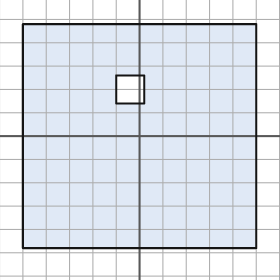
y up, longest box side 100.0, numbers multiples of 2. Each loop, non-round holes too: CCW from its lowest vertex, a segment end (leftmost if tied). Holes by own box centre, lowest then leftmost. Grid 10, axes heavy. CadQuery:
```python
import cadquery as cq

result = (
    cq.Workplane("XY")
    .moveTo(-50.0, -48.0)
    .lineTo(50.0, -48.0)
    .lineTo(50.0, 48.0)
    .lineTo(-50.0, 48.0)
    .close()
    .moveTo(-10.0, 14.0)
    .lineTo(2.0, 14.0)
    .lineTo(2.0, 26.0)
    .lineTo(-10.0, 26.0)
    .close()
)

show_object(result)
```